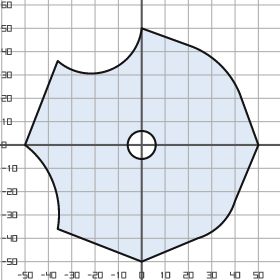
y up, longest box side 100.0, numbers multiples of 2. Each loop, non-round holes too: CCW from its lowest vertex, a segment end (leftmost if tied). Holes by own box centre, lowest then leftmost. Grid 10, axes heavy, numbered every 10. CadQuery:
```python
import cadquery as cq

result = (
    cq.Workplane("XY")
    .moveTo(0.0, -50.0)
    .lineTo(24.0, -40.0)
    .threePointArc((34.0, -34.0), (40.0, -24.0))
    .lineTo(50.0, 0.0)
    .lineTo(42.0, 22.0)
    .threePointArc((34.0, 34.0), (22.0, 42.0))
    .lineTo(0.0, 50.0)
    .threePointArc((-14.0, 32.0), (-36.0, 36.0))
    .lineTo(-50.0, 0.0)
    .threePointArc((-38.0, -16.0), (-36.0, -36.0))
    .close()
    .moveTo(0.0, 0.0)
    .circle(6.0)
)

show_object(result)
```